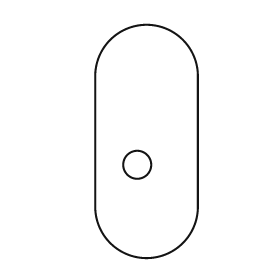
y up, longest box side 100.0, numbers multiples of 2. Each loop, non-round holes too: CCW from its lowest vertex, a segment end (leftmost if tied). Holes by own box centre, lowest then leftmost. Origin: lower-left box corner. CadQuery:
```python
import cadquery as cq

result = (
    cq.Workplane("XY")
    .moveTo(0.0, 22.0)
    .threePointArc((22.0, 0.0), (44.0, 22.0))
    .lineTo(44.0, 78.0)
    .threePointArc((22.0, 100.0), (0.0, 78.0))
    .close()
    .moveTo(18.0, 40.0)
    .circle(6.0)
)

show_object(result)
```